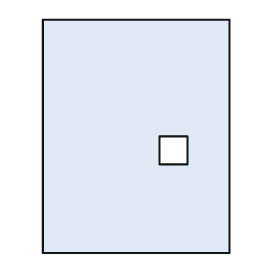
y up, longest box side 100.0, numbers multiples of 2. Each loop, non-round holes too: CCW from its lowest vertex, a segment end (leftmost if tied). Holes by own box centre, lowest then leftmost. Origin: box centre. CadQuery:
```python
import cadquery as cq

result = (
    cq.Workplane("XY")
    .moveTo(-40.0, -50.0)
    .lineTo(40.0, -50.0)
    .lineTo(40.0, 50.0)
    .lineTo(-40.0, 50.0)
    .close()
    .moveTo(10.0, -12.0)
    .lineTo(22.0, -12.0)
    .lineTo(22.0, 0.0)
    .lineTo(10.0, 0.0)
    .close()
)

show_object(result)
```